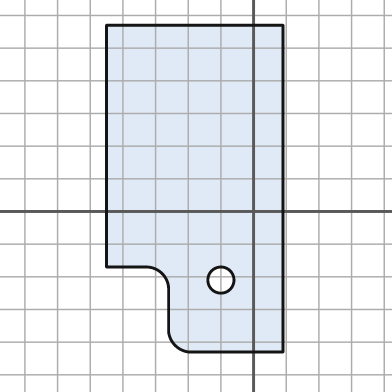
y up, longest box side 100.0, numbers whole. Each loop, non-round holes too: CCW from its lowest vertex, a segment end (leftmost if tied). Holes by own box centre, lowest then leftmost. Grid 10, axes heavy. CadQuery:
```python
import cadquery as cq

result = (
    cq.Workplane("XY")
    .moveTo(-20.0, -43.0)
    .lineTo(9.0, -43.0)
    .lineTo(9.0, 57.0)
    .lineTo(-45.0, 57.0)
    .lineTo(-45.0, -17.0)
    .lineTo(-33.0, -17.0)
    .threePointArc((-28.0, -19.0), (-26.0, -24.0))
    .lineTo(-26.0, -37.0)
    .threePointArc((-24.0, -41.0), (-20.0, -43.0))
    .close()
    .moveTo(-10.0, -21.0)
    .circle(4.0)
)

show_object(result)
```